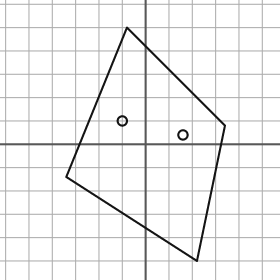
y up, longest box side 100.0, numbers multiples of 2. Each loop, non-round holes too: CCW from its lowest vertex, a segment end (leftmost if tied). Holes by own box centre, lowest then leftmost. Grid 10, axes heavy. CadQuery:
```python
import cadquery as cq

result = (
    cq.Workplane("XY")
    .moveTo(22.0, -50.0)
    .lineTo(34.0, 8.0)
    .lineTo(-8.0, 50.0)
    .lineTo(-34.0, -14.0)
    .close()
    .moveTo(16.0, 4.0)
    .circle(2.0)
    .moveTo(-10.0, 10.0)
    .circle(2.0)
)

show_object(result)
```